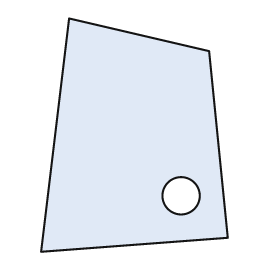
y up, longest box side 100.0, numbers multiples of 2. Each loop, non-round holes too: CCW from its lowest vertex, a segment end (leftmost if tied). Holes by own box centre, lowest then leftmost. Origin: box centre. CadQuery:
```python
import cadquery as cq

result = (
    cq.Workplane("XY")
    .moveTo(-40.0, -50.0)
    .lineTo(40.0, -44.0)
    .lineTo(32.0, 36.0)
    .lineTo(-28.0, 50.0)
    .close()
    .moveTo(20.0, -26.0)
    .circle(8.0)
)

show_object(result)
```